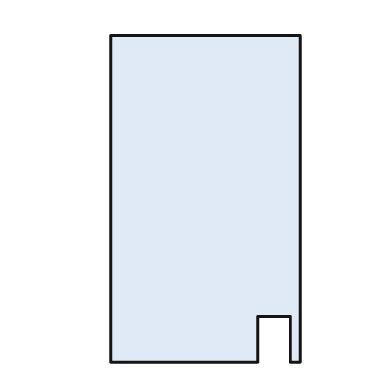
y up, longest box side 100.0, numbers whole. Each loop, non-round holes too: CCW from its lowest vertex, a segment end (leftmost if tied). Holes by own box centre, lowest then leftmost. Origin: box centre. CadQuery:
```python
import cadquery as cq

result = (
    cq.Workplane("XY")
    .moveTo(-29.0, -50.0)
    .lineTo(16.0, -50.0)
    .lineTo(16.0, -36.0)
    .lineTo(26.0, -36.0)
    .lineTo(26.0, -50.0)
    .lineTo(29.0, -50.0)
    .lineTo(29.0, 50.0)
    .lineTo(-29.0, 50.0)
    .close()
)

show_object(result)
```